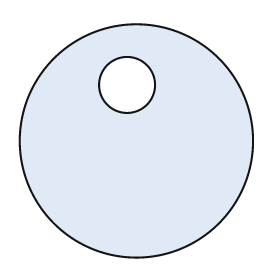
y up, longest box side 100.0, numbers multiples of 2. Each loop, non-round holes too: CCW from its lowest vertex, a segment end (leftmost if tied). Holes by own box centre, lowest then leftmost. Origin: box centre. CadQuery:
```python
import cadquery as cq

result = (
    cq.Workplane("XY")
    .moveTo(0.0, 0.0)
    .circle(50.0)
    .moveTo(-4.0, 24.0)
    .circle(12.0)
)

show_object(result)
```